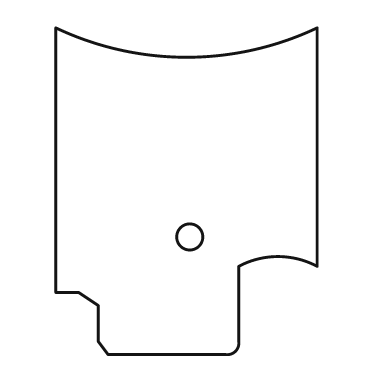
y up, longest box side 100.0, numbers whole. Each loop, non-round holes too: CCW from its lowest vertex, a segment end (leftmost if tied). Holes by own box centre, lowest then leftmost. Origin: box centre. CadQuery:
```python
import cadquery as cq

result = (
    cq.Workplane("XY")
    .moveTo(-24.0, -50.0)
    .lineTo(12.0, -50.0)
    .threePointArc((15.0, -49.0), (16.0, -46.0))
    .lineTo(16.0, -23.0)
    .threePointArc((28.0, -20.0), (40.0, -23.0))
    .lineTo(40.0, 50.0)
    .threePointArc((0.0, 41.0), (-40.0, 50.0))
    .lineTo(-40.0, -31.0)
    .lineTo(-33.0, -31.0)
    .lineTo(-27.0, -35.0)
    .lineTo(-27.0, -46.0)
    .close()
    .moveTo(1.0, -14.0)
    .circle(4.0)
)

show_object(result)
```